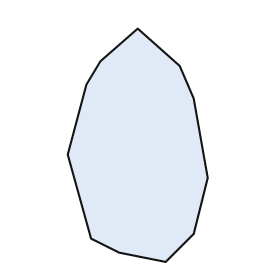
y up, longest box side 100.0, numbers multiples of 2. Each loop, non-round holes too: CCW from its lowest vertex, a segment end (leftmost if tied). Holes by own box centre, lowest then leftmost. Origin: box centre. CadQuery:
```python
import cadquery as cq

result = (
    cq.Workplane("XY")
    .moveTo(12.0, -50.0)
    .lineTo(24.0, -38.0)
    .lineTo(30.0, -14.0)
    .lineTo(24.0, 20.0)
    .lineTo(18.0, 34.0)
    .lineTo(0.0, 50.0)
    .lineTo(-16.0, 36.0)
    .lineTo(-22.0, 26.0)
    .lineTo(-30.0, -4.0)
    .lineTo(-20.0, -40.0)
    .lineTo(-8.0, -46.0)
    .close()
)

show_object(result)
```